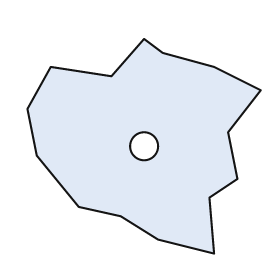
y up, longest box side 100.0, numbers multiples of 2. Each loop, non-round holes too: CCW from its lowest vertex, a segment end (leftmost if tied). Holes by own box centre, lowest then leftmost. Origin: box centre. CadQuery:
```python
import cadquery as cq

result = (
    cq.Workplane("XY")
    .moveTo(30.0, -46.0)
    .lineTo(28.0, -22.0)
    .lineTo(40.0, -14.0)
    .lineTo(36.0, 6.0)
    .lineTo(50.0, 24.0)
    .lineTo(30.0, 34.0)
    .lineTo(8.0, 40.0)
    .lineTo(0.0, 46.0)
    .lineTo(-14.0, 30.0)
    .lineTo(-40.0, 34.0)
    .lineTo(-50.0, 16.0)
    .lineTo(-46.0, -4.0)
    .lineTo(-28.0, -26.0)
    .lineTo(-10.0, -30.0)
    .lineTo(6.0, -40.0)
    .close()
    .moveTo(0.0, 0.0)
    .circle(6.0)
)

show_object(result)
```